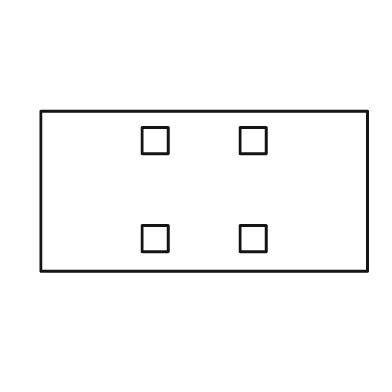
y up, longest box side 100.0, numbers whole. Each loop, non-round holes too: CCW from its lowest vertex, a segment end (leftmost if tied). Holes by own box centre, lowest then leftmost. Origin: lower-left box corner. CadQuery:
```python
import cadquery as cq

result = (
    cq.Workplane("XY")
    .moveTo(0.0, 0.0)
    .lineTo(100.0, 0.0)
    .lineTo(100.0, 49.0)
    .lineTo(0.0, 49.0)
    .close()
    .moveTo(31.0, 6.0)
    .lineTo(39.0, 6.0)
    .lineTo(39.0, 14.0)
    .lineTo(31.0, 14.0)
    .close()
    .moveTo(61.0, 6.0)
    .lineTo(69.0, 6.0)
    .lineTo(69.0, 14.0)
    .lineTo(61.0, 14.0)
    .close()
    .moveTo(31.0, 36.0)
    .lineTo(39.0, 36.0)
    .lineTo(39.0, 44.0)
    .lineTo(31.0, 44.0)
    .close()
    .moveTo(61.0, 36.0)
    .lineTo(69.0, 36.0)
    .lineTo(69.0, 44.0)
    .lineTo(61.0, 44.0)
    .close()
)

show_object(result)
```